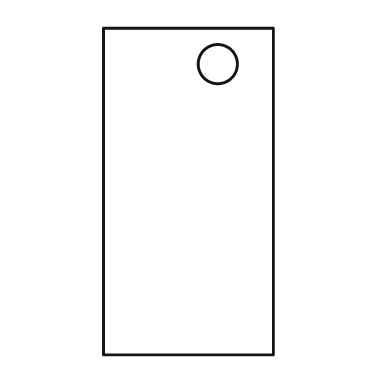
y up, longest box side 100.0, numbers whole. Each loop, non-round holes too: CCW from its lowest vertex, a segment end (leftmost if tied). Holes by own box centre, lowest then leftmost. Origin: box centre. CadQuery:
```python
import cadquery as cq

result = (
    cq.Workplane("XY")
    .moveTo(-26.0, -50.0)
    .lineTo(26.0, -50.0)
    .lineTo(26.0, 50.0)
    .lineTo(-26.0, 50.0)
    .close()
    .moveTo(9.0, 39.0)
    .circle(6.0)
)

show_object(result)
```